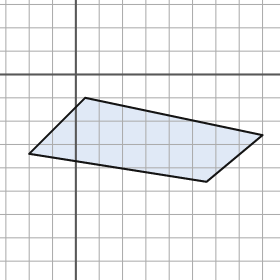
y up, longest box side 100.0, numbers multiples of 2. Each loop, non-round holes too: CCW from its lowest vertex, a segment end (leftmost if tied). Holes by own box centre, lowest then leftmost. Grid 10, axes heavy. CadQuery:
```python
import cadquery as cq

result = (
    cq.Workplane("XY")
    .moveTo(56.0, -46.0)
    .lineTo(80.0, -26.0)
    .lineTo(4.0, -10.0)
    .lineTo(-20.0, -34.0)
    .close()
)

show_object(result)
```